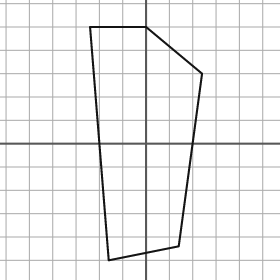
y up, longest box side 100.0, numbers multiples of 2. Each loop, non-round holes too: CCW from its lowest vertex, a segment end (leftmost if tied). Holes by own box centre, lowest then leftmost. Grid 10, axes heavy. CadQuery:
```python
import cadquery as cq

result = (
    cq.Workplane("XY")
    .moveTo(-16.0, -50.0)
    .lineTo(14.0, -44.0)
    .lineTo(24.0, 30.0)
    .lineTo(0.0, 50.0)
    .lineTo(-24.0, 50.0)
    .close()
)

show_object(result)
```